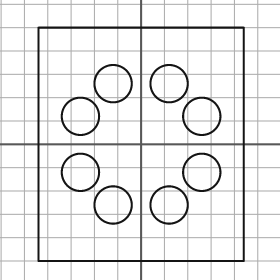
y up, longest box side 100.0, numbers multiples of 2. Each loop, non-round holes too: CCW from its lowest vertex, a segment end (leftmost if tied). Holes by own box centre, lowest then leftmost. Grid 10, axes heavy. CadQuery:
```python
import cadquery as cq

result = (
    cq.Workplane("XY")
    .moveTo(-44.0, -50.0)
    .lineTo(44.0, -50.0)
    .lineTo(44.0, 50.0)
    .lineTo(-44.0, 50.0)
    .close()
    .moveTo(-12.0, -26.0)
    .circle(8.0)
    .moveTo(12.0, -26.0)
    .circle(8.0)
    .moveTo(-26.0, -12.0)
    .circle(8.0)
    .moveTo(26.0, -12.0)
    .circle(8.0)
    .moveTo(-26.0, 12.0)
    .circle(8.0)
    .moveTo(26.0, 12.0)
    .circle(8.0)
    .moveTo(-12.0, 26.0)
    .circle(8.0)
    .moveTo(12.0, 26.0)
    .circle(8.0)
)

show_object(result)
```